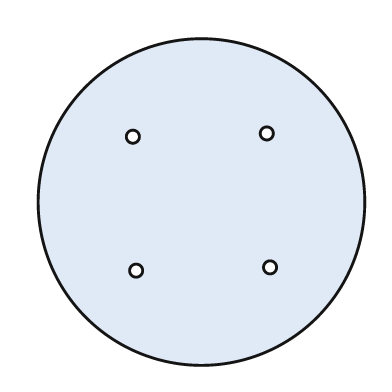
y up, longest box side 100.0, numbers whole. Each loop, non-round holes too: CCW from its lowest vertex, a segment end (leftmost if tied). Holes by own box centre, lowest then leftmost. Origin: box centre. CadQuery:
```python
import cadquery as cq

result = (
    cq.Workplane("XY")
    .moveTo(0.0, 0.0)
    .circle(50.0)
    .moveTo(-20.0, -21.0)
    .circle(2.0)
    .moveTo(21.0, -20.0)
    .circle(2.0)
    .moveTo(-21.0, 20.0)
    .circle(2.0)
    .moveTo(20.0, 21.0)
    .circle(2.0)
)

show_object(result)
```